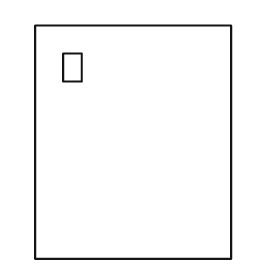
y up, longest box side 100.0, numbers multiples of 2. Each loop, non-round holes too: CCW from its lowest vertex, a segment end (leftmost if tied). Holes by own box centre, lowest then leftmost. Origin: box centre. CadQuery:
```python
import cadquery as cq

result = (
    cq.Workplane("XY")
    .moveTo(-42.0, -50.0)
    .lineTo(42.0, -50.0)
    .lineTo(42.0, 50.0)
    .lineTo(-42.0, 50.0)
    .close()
    .moveTo(-30.0, 26.0)
    .lineTo(-22.0, 26.0)
    .lineTo(-22.0, 38.0)
    .lineTo(-30.0, 38.0)
    .close()
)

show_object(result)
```